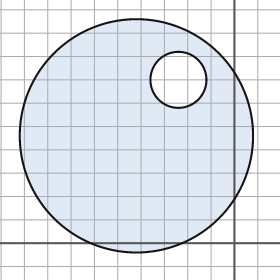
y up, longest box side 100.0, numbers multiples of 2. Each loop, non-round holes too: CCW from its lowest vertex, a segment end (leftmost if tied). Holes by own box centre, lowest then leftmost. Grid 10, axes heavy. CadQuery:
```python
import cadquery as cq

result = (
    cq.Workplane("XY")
    .moveTo(-42.0, 46.0)
    .circle(50.0)
    .moveTo(-24.0, 70.0)
    .circle(12.0)
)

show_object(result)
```